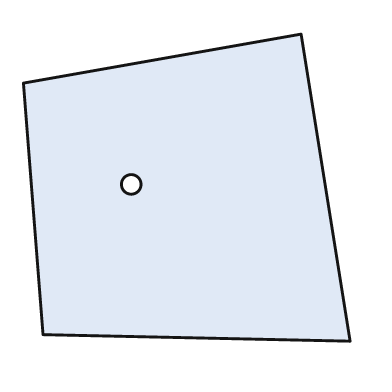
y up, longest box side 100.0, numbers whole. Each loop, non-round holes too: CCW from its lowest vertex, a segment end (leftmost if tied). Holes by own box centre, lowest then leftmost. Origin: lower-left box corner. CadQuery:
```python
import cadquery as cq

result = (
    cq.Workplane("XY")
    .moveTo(100.0, 0.0)
    .lineTo(85.0, 94.0)
    .lineTo(0.0, 79.0)
    .lineTo(6.0, 2.0)
    .close()
    .moveTo(33.0, 48.0)
    .circle(3.0)
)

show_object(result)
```